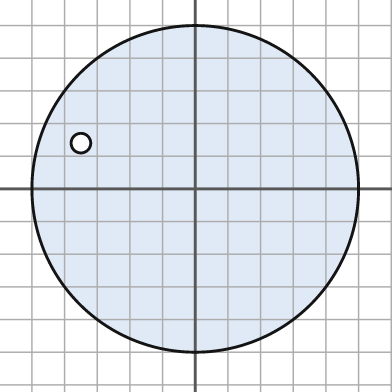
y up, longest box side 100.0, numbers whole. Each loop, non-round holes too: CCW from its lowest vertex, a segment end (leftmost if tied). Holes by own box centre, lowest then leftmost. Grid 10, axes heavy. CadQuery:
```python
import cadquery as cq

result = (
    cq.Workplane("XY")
    .moveTo(0.0, 0.0)
    .circle(50.0)
    .moveTo(-35.0, 14.0)
    .circle(3.0)
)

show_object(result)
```